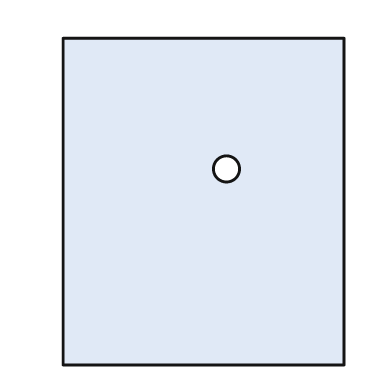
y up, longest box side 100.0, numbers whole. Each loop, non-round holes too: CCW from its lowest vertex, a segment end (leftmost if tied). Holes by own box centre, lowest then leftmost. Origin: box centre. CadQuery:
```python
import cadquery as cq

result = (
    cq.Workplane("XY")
    .moveTo(-43.0, -50.0)
    .lineTo(43.0, -50.0)
    .lineTo(43.0, 50.0)
    .lineTo(-43.0, 50.0)
    .close()
    .moveTo(7.0, 10.0)
    .circle(4.0)
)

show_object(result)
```